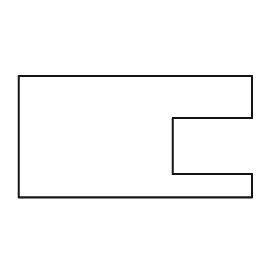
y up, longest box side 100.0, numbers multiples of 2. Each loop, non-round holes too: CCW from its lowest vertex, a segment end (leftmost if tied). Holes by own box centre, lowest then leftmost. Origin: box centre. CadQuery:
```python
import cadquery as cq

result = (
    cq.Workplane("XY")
    .moveTo(-50.0, -26.0)
    .lineTo(50.0, -26.0)
    .lineTo(50.0, -16.0)
    .lineTo(16.0, -16.0)
    .lineTo(16.0, 8.0)
    .lineTo(50.0, 8.0)
    .lineTo(50.0, 26.0)
    .lineTo(-50.0, 26.0)
    .close()
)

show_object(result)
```